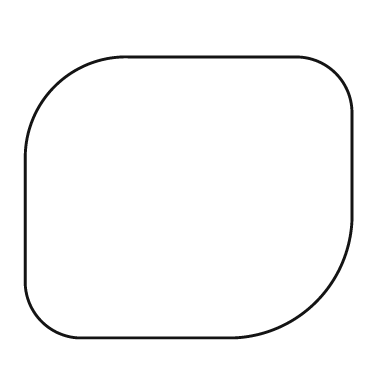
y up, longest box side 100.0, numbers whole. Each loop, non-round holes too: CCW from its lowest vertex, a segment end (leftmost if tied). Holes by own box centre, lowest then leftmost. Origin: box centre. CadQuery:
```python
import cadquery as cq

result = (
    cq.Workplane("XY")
    .moveTo(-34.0, -43.0)
    .lineTo(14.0, -43.0)
    .threePointArc((39.0, -32.0), (50.0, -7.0))
    .lineTo(50.0, 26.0)
    .threePointArc((45.0, 38.0), (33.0, 43.0))
    .lineTo(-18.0, 43.0)
    .threePointArc((-41.0, 34.0), (-50.0, 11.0))
    .lineTo(-50.0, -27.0)
    .threePointArc((-45.0, -38.0), (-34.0, -43.0))
    .close()
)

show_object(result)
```